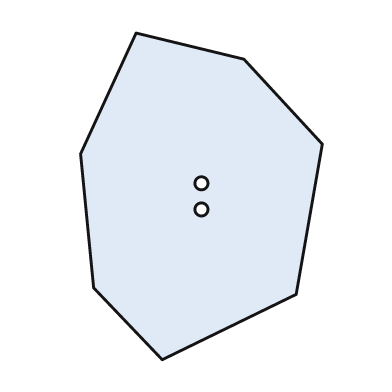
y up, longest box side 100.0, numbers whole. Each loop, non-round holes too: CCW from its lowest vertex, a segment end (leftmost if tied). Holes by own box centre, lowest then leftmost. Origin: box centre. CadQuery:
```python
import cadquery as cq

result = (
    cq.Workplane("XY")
    .moveTo(-12.0, -50.0)
    .lineTo(29.0, -30.0)
    .lineTo(37.0, 16.0)
    .lineTo(13.0, 42.0)
    .lineTo(-20.0, 50.0)
    .lineTo(-37.0, 13.0)
    .lineTo(-33.0, -28.0)
    .close()
    .moveTo(0.0, -4.0)
    .circle(2.0)
    .moveTo(0.0, 4.0)
    .circle(2.0)
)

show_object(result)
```